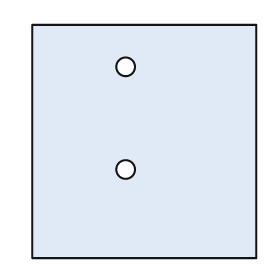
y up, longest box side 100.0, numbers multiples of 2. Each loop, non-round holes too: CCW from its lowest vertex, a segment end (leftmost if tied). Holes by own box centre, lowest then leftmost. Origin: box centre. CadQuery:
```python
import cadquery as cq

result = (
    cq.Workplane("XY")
    .moveTo(-48.0, -50.0)
    .lineTo(48.0, -50.0)
    .lineTo(48.0, 50.0)
    .lineTo(-48.0, 50.0)
    .close()
    .moveTo(-8.0, -12.0)
    .circle(4.0)
    .moveTo(-8.0, 32.0)
    .circle(4.0)
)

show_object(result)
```